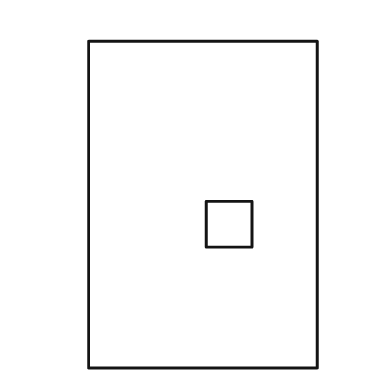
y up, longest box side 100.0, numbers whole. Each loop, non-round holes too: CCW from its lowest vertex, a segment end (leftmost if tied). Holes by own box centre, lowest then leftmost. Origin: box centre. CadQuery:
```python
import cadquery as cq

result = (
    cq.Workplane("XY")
    .moveTo(-35.0, -50.0)
    .lineTo(35.0, -50.0)
    .lineTo(35.0, 50.0)
    .lineTo(-35.0, 50.0)
    .close()
    .moveTo(1.0, -13.0)
    .lineTo(15.0, -13.0)
    .lineTo(15.0, 1.0)
    .lineTo(1.0, 1.0)
    .close()
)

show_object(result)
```